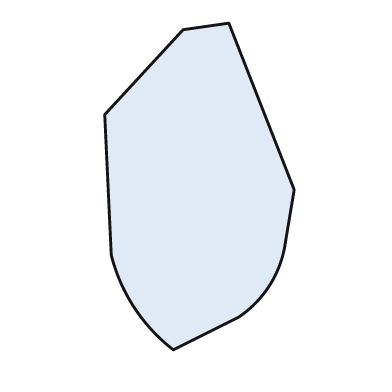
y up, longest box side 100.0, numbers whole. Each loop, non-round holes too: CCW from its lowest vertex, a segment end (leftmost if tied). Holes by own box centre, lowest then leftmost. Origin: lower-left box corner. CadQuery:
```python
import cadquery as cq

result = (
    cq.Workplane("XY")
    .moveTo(21.0, 0.0)
    .lineTo(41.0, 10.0)
    .threePointArc((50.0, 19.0), (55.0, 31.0))
    .lineTo(58.0, 49.0)
    .lineTo(38.0, 100.0)
    .lineTo(24.0, 98.0)
    .lineTo(0.0, 72.0)
    .lineTo(2.0, 29.0)
    .threePointArc((9.0, 13.0), (21.0, 0.0))
    .close()
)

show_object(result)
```